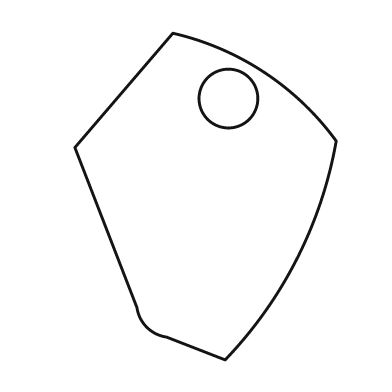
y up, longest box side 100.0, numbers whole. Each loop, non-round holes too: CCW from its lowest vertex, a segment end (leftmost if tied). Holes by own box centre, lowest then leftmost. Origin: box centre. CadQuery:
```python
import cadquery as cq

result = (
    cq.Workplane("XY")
    .moveTo(6.0, -50.0)
    .threePointArc((28.0, -19.0), (40.0, 17.0))
    .threePointArc((18.0, 38.0), (-10.0, 50.0))
    .lineTo(-40.0, 15.0)
    .lineTo(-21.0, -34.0)
    .threePointArc((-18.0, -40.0), (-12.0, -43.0))
    .close()
    .moveTo(7.0, 30.0)
    .circle(9.0)
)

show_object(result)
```